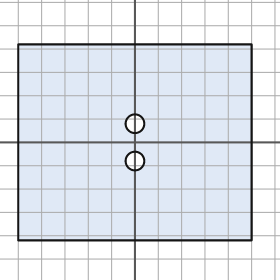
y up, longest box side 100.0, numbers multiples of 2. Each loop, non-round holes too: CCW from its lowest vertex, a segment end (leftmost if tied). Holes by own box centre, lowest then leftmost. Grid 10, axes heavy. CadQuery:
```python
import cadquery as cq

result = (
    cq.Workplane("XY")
    .moveTo(-50.0, -42.0)
    .lineTo(50.0, -42.0)
    .lineTo(50.0, 42.0)
    .lineTo(-50.0, 42.0)
    .close()
    .moveTo(0.0, -8.0)
    .circle(4.0)
    .moveTo(0.0, 8.0)
    .circle(4.0)
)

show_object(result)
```